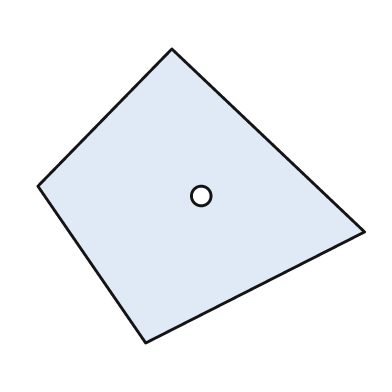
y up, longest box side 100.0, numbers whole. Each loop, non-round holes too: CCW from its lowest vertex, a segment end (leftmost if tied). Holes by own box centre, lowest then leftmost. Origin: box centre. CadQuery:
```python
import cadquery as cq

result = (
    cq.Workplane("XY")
    .moveTo(-17.0, -45.0)
    .lineTo(50.0, -11.0)
    .lineTo(-9.0, 45.0)
    .lineTo(-50.0, 3.0)
    .close()
    .moveTo(0.0, 0.0)
    .circle(3.0)
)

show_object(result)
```